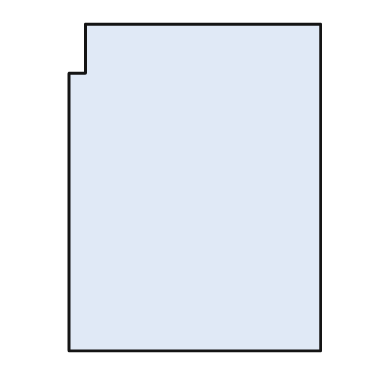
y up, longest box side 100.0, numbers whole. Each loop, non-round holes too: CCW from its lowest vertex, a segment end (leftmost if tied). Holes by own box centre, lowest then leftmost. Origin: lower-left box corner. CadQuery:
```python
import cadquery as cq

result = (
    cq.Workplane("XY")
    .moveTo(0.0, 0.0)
    .lineTo(77.0, 0.0)
    .lineTo(77.0, 100.0)
    .lineTo(5.0, 100.0)
    .lineTo(5.0, 85.0)
    .lineTo(0.0, 85.0)
    .close()
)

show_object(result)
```